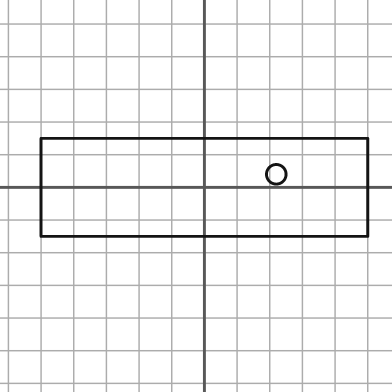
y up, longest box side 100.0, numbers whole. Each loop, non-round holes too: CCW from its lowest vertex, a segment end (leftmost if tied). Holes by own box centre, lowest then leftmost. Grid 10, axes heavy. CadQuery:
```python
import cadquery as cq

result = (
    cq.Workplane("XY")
    .moveTo(-50.0, -15.0)
    .lineTo(50.0, -15.0)
    .lineTo(50.0, 15.0)
    .lineTo(-50.0, 15.0)
    .close()
    .moveTo(22.0, 4.0)
    .circle(3.0)
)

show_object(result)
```